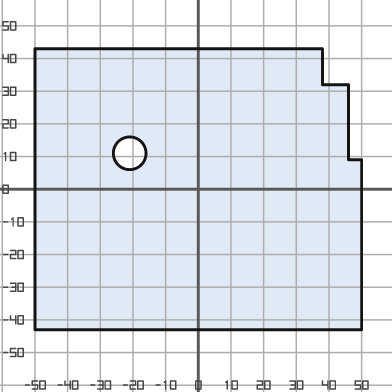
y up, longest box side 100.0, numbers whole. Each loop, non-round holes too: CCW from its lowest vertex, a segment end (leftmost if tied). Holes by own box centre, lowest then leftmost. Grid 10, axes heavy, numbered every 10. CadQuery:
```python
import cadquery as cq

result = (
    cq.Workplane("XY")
    .moveTo(-50.0, -43.0)
    .lineTo(50.0, -43.0)
    .lineTo(50.0, 9.0)
    .lineTo(46.0, 9.0)
    .lineTo(46.0, 32.0)
    .lineTo(38.0, 32.0)
    .lineTo(38.0, 43.0)
    .lineTo(-50.0, 43.0)
    .close()
    .moveTo(-21.0, 11.0)
    .circle(5.0)
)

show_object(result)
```